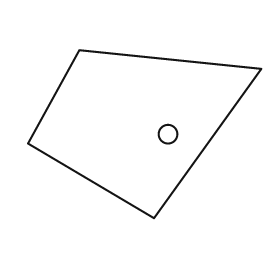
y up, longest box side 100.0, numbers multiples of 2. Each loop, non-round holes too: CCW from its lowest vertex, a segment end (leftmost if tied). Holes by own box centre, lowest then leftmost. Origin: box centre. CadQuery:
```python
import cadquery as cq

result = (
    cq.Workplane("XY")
    .moveTo(4.0, -36.0)
    .lineTo(50.0, 28.0)
    .lineTo(-28.0, 36.0)
    .lineTo(-50.0, -4.0)
    .close()
    .moveTo(10.0, 0.0)
    .circle(4.0)
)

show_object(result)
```